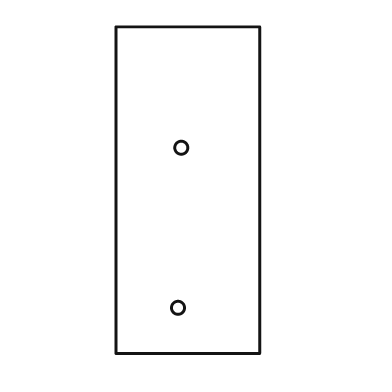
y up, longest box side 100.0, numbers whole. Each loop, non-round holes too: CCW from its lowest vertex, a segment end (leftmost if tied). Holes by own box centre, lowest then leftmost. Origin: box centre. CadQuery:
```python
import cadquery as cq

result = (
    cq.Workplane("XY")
    .moveTo(-22.0, -50.0)
    .lineTo(22.0, -50.0)
    .lineTo(22.0, 50.0)
    .lineTo(-22.0, 50.0)
    .close()
    .moveTo(-3.0, -36.0)
    .circle(2.0)
    .moveTo(-2.0, 13.0)
    .circle(2.0)
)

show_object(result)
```